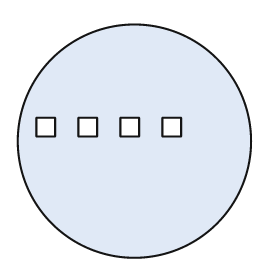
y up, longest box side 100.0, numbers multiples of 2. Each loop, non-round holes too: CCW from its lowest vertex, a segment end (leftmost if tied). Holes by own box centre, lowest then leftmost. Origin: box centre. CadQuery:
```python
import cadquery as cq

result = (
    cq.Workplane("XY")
    .moveTo(0.0, 0.0)
    .circle(50.0)
    .moveTo(-42.0, 2.0)
    .lineTo(-34.0, 2.0)
    .lineTo(-34.0, 10.0)
    .lineTo(-42.0, 10.0)
    .close()
    .moveTo(-24.0, 2.0)
    .lineTo(-16.0, 2.0)
    .lineTo(-16.0, 10.0)
    .lineTo(-24.0, 10.0)
    .close()
    .moveTo(-6.0, 2.0)
    .lineTo(2.0, 2.0)
    .lineTo(2.0, 10.0)
    .lineTo(-6.0, 10.0)
    .close()
    .moveTo(12.0, 2.0)
    .lineTo(20.0, 2.0)
    .lineTo(20.0, 10.0)
    .lineTo(12.0, 10.0)
    .close()
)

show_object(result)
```